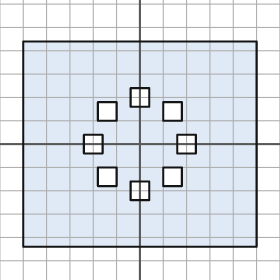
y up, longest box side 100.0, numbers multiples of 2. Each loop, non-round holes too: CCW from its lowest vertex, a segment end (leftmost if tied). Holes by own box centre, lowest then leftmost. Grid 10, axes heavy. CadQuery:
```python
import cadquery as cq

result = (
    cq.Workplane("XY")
    .moveTo(-50.0, -44.0)
    .lineTo(50.0, -44.0)
    .lineTo(50.0, 44.0)
    .lineTo(-50.0, 44.0)
    .close()
    .moveTo(-4.0, -24.0)
    .lineTo(4.0, -24.0)
    .lineTo(4.0, -16.0)
    .lineTo(-4.0, -16.0)
    .close()
    .moveTo(-18.0, -18.0)
    .lineTo(-10.0, -18.0)
    .lineTo(-10.0, -10.0)
    .lineTo(-18.0, -10.0)
    .close()
    .moveTo(10.0, -18.0)
    .lineTo(18.0, -18.0)
    .lineTo(18.0, -10.0)
    .lineTo(10.0, -10.0)
    .close()
    .moveTo(-24.0, -4.0)
    .lineTo(-16.0, -4.0)
    .lineTo(-16.0, 4.0)
    .lineTo(-24.0, 4.0)
    .close()
    .moveTo(16.0, -4.0)
    .lineTo(24.0, -4.0)
    .lineTo(24.0, 4.0)
    .lineTo(16.0, 4.0)
    .close()
    .moveTo(-18.0, 10.0)
    .lineTo(-10.0, 10.0)
    .lineTo(-10.0, 18.0)
    .lineTo(-18.0, 18.0)
    .close()
    .moveTo(10.0, 10.0)
    .lineTo(18.0, 10.0)
    .lineTo(18.0, 18.0)
    .lineTo(10.0, 18.0)
    .close()
    .moveTo(-4.0, 16.0)
    .lineTo(4.0, 16.0)
    .lineTo(4.0, 24.0)
    .lineTo(-4.0, 24.0)
    .close()
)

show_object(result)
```